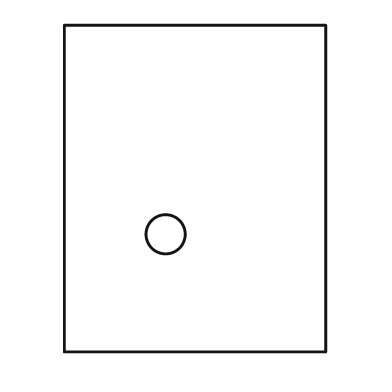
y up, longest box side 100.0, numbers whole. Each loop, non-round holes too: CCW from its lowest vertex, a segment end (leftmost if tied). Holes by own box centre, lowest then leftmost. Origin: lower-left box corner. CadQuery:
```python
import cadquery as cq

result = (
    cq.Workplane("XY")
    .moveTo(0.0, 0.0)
    .lineTo(80.0, 0.0)
    .lineTo(80.0, 100.0)
    .lineTo(0.0, 100.0)
    .close()
    .moveTo(31.0, 36.0)
    .circle(6.0)
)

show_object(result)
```